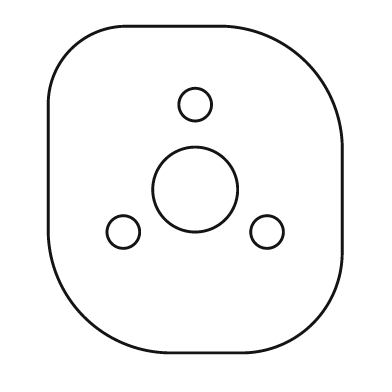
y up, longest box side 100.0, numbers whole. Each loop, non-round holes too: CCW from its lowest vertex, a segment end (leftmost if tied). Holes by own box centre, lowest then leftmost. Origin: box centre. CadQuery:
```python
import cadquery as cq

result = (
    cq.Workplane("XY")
    .moveTo(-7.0, -50.0)
    .lineTo(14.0, -50.0)
    .threePointArc((36.0, -41.0), (45.0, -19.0))
    .lineTo(45.0, 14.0)
    .threePointArc((34.0, 39.0), (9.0, 50.0))
    .lineTo(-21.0, 50.0)
    .threePointArc((-38.0, 43.0), (-45.0, 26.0))
    .lineTo(-45.0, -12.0)
    .threePointArc((-34.0, -39.0), (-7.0, -50.0))
    .close()
    .moveTo(-22.0, -13.0)
    .circle(5.0)
    .moveTo(22.0, -13.0)
    .circle(5.0)
    .moveTo(0.0, 0.0)
    .circle(13.0)
    .moveTo(0.0, 26.0)
    .circle(5.0)
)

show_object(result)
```